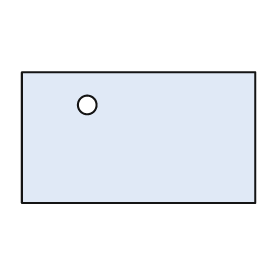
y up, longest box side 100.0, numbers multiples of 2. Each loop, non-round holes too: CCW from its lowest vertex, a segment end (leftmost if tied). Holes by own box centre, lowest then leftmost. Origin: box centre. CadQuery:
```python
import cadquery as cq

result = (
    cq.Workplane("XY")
    .moveTo(-50.0, -28.0)
    .lineTo(50.0, -28.0)
    .lineTo(50.0, 28.0)
    .lineTo(-50.0, 28.0)
    .close()
    .moveTo(-22.0, 14.0)
    .circle(4.0)
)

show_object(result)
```